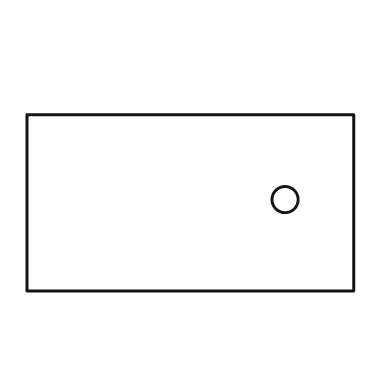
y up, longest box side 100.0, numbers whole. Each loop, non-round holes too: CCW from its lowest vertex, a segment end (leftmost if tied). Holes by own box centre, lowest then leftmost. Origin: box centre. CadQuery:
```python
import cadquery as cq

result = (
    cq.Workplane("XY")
    .moveTo(-50.0, -27.0)
    .lineTo(50.0, -27.0)
    .lineTo(50.0, 27.0)
    .lineTo(-50.0, 27.0)
    .close()
    .moveTo(29.0, 1.0)
    .circle(4.0)
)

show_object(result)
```